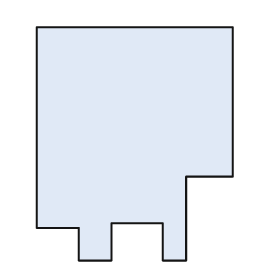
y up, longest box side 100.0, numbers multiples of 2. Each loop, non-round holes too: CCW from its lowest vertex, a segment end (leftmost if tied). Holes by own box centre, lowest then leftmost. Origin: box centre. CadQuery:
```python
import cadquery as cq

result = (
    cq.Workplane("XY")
    .moveTo(-24.0, -50.0)
    .lineTo(-10.0, -50.0)
    .lineTo(-10.0, -34.0)
    .lineTo(12.0, -34.0)
    .lineTo(12.0, -50.0)
    .lineTo(22.0, -50.0)
    .lineTo(22.0, -14.0)
    .lineTo(42.0, -14.0)
    .lineTo(42.0, 50.0)
    .lineTo(-42.0, 50.0)
    .lineTo(-42.0, -36.0)
    .lineTo(-24.0, -36.0)
    .close()
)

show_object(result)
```